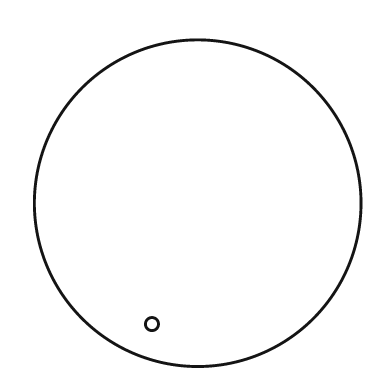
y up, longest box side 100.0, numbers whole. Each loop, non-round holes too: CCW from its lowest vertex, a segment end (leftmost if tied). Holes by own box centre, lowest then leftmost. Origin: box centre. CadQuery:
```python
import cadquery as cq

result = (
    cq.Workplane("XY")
    .moveTo(0.0, 0.0)
    .circle(50.0)
    .moveTo(-14.0, -37.0)
    .circle(2.0)
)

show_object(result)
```